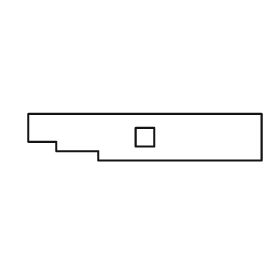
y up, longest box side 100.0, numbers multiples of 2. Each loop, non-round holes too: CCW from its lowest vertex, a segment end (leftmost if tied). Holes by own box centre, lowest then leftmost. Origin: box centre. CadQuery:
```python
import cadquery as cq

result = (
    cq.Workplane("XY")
    .moveTo(-20.0, -10.0)
    .lineTo(50.0, -10.0)
    .lineTo(50.0, 10.0)
    .lineTo(-50.0, 10.0)
    .lineTo(-50.0, -2.0)
    .lineTo(-38.0, -2.0)
    .lineTo(-38.0, -6.0)
    .lineTo(-20.0, -6.0)
    .close()
    .moveTo(-4.0, -4.0)
    .lineTo(4.0, -4.0)
    .lineTo(4.0, 4.0)
    .lineTo(-4.0, 4.0)
    .close()
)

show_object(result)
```